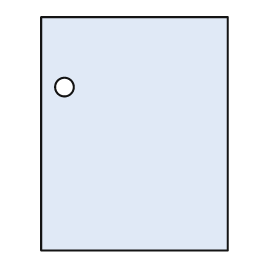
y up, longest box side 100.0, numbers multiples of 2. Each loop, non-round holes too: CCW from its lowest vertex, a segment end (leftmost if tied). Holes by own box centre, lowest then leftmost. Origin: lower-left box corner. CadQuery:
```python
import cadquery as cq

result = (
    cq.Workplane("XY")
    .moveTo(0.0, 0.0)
    .lineTo(80.0, 0.0)
    .lineTo(80.0, 100.0)
    .lineTo(0.0, 100.0)
    .close()
    .moveTo(10.0, 70.0)
    .circle(4.0)
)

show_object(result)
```